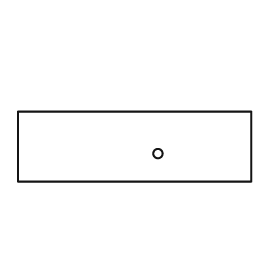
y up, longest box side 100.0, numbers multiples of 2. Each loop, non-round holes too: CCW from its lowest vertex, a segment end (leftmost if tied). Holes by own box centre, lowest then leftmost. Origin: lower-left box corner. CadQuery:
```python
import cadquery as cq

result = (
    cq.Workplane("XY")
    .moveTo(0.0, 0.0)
    .lineTo(100.0, 0.0)
    .lineTo(100.0, 30.0)
    .lineTo(0.0, 30.0)
    .close()
    .moveTo(60.0, 12.0)
    .circle(2.0)
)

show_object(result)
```